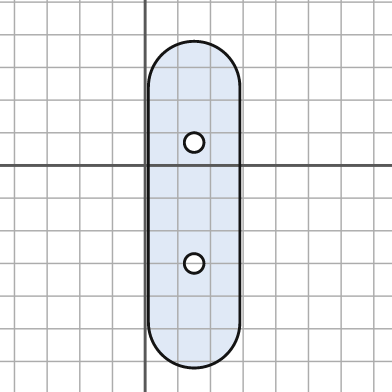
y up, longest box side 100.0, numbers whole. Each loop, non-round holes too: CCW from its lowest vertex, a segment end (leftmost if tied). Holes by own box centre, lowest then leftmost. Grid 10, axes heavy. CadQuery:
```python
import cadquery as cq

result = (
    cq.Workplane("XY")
    .moveTo(1.0, -48.0)
    .threePointArc((15.0, -62.0), (29.0, -48.0))
    .lineTo(29.0, 24.0)
    .threePointArc((15.0, 38.0), (1.0, 24.0))
    .close()
    .moveTo(15.0, -30.0)
    .circle(3.0)
    .moveTo(15.0, 7.0)
    .circle(3.0)
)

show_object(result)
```